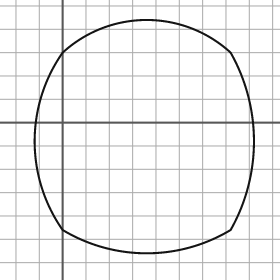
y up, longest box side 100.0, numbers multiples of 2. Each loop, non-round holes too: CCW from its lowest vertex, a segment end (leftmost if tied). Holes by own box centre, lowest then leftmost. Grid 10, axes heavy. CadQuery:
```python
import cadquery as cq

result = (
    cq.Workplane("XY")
    .moveTo(0.0, -46.0)
    .threePointArc((36.0, -56.0), (72.0, -46.0))
    .threePointArc((82.0, -8.0), (72.0, 30.0))
    .threePointArc((36.0, 44.0), (0.0, 30.0))
    .threePointArc((-12.0, -8.0), (0.0, -46.0))
    .close()
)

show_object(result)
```